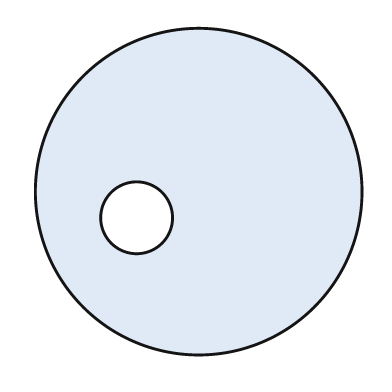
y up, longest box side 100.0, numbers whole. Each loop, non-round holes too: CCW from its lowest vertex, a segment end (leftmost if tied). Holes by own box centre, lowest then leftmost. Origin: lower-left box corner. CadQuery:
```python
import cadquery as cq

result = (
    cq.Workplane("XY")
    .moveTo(50.0, 50.0)
    .circle(50.0)
    .moveTo(31.0, 42.0)
    .circle(11.0)
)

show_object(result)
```